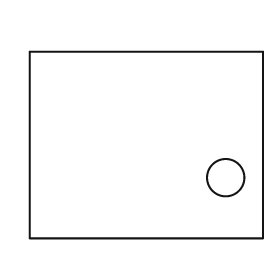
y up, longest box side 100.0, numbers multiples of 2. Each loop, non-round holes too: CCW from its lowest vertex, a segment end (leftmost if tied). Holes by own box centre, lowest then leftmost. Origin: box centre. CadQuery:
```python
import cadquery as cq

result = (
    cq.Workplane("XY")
    .moveTo(-50.0, -40.0)
    .lineTo(50.0, -40.0)
    .lineTo(50.0, 40.0)
    .lineTo(-50.0, 40.0)
    .close()
    .moveTo(34.0, -14.0)
    .circle(8.0)
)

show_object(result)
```